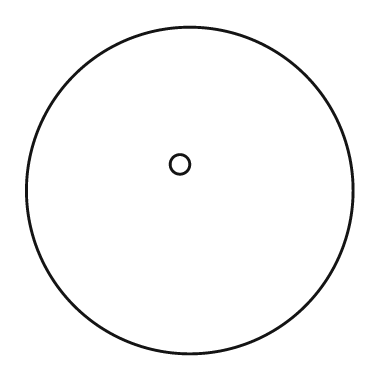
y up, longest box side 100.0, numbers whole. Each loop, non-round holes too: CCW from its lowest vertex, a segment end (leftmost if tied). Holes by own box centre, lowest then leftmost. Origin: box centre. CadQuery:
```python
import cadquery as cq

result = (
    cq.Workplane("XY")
    .moveTo(0.0, 0.0)
    .circle(50.0)
    .moveTo(-3.0, 8.0)
    .circle(3.0)
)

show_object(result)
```